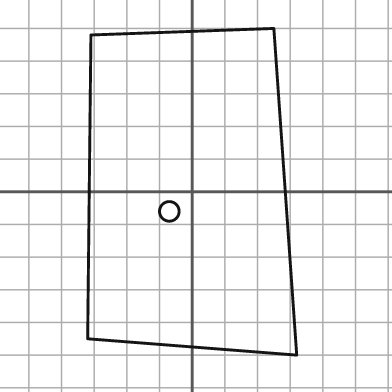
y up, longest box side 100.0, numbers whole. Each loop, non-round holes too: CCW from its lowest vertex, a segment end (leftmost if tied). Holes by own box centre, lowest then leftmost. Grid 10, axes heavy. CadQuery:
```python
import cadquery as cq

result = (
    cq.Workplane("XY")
    .moveTo(32.0, -50.0)
    .lineTo(25.0, 50.0)
    .lineTo(-31.0, 48.0)
    .lineTo(-32.0, -45.0)
    .close()
    .moveTo(-7.0, -6.0)
    .circle(3.0)
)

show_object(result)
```